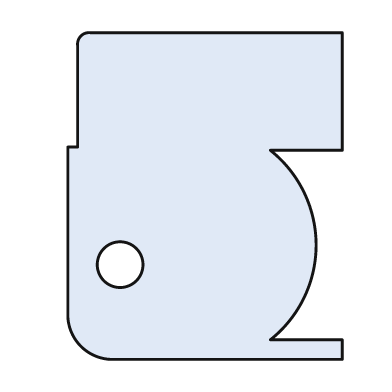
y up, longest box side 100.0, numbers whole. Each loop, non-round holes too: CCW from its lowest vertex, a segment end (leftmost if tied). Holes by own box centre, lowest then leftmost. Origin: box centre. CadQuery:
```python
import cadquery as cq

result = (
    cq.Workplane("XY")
    .moveTo(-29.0, -50.0)
    .lineTo(42.0, -50.0)
    .lineTo(42.0, -44.0)
    .lineTo(20.0, -44.0)
    .threePointArc((34.0, -15.0), (20.0, 14.0))
    .lineTo(42.0, 14.0)
    .lineTo(42.0, 50.0)
    .lineTo(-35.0, 50.0)
    .threePointArc((-38.0, 49.0), (-39.0, 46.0))
    .lineTo(-39.0, 15.0)
    .lineTo(-42.0, 15.0)
    .lineTo(-42.0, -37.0)
    .threePointArc((-38.0, -46.0), (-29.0, -50.0))
    .close()
    .moveTo(-26.0, -21.0)
    .circle(7.0)
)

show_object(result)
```